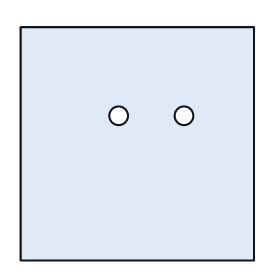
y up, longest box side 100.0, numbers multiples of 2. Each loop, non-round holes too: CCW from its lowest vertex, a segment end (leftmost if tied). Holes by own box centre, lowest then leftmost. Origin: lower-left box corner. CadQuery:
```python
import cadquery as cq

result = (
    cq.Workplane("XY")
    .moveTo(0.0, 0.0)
    .lineTo(100.0, 0.0)
    .lineTo(100.0, 100.0)
    .lineTo(0.0, 100.0)
    .close()
    .moveTo(42.0, 62.0)
    .circle(4.0)
    .moveTo(70.0, 62.0)
    .circle(4.0)
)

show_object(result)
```